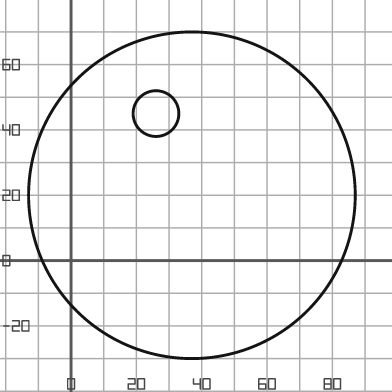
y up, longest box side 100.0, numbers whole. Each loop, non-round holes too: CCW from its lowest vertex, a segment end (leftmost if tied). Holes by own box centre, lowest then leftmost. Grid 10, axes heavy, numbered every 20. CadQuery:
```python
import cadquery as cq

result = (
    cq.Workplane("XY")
    .moveTo(37.0, 20.0)
    .circle(50.0)
    .moveTo(26.0, 45.0)
    .circle(7.0)
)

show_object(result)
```